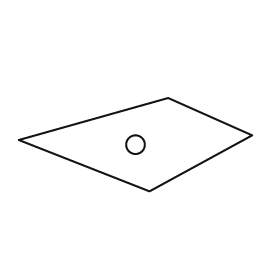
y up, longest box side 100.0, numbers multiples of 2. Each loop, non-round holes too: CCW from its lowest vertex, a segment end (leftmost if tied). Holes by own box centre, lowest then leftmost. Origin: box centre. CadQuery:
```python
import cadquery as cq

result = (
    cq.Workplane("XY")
    .moveTo(6.0, -20.0)
    .lineTo(50.0, 4.0)
    .lineTo(14.0, 20.0)
    .lineTo(-50.0, 2.0)
    .close()
    .moveTo(0.0, 0.0)
    .circle(4.0)
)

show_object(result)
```